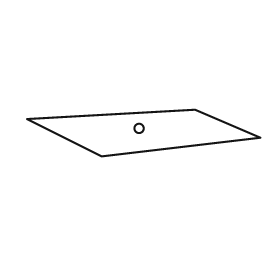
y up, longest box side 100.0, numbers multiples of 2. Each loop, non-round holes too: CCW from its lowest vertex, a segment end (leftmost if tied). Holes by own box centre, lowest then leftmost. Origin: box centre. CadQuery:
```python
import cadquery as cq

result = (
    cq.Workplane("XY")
    .moveTo(-18.0, -10.0)
    .lineTo(50.0, -2.0)
    .lineTo(22.0, 10.0)
    .lineTo(-50.0, 6.0)
    .close()
    .moveTo(-2.0, 2.0)
    .circle(2.0)
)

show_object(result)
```